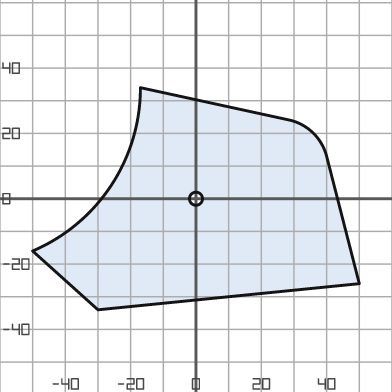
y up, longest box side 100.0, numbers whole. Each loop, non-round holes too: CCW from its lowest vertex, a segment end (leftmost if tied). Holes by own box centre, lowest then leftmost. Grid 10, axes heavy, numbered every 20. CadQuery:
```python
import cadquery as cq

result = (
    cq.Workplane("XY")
    .moveTo(-30.0, -34.0)
    .lineTo(50.0, -26.0)
    .lineTo(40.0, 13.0)
    .threePointArc((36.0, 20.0), (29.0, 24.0))
    .lineTo(-17.0, 34.0)
    .threePointArc((-26.0, 4.0), (-50.0, -16.0))
    .close()
    .moveTo(0.0, 0.0)
    .circle(2.0)
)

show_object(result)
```